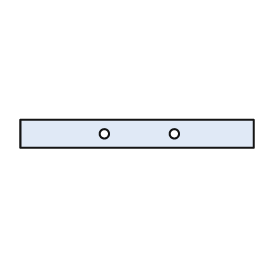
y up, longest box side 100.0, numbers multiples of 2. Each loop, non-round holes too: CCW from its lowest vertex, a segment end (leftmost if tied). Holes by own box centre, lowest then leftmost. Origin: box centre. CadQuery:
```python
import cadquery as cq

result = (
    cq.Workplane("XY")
    .moveTo(-50.0, -6.0)
    .lineTo(50.0, -6.0)
    .lineTo(50.0, 6.0)
    .lineTo(-50.0, 6.0)
    .close()
    .moveTo(-14.0, 0.0)
    .circle(2.0)
    .moveTo(16.0, 0.0)
    .circle(2.0)
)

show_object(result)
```